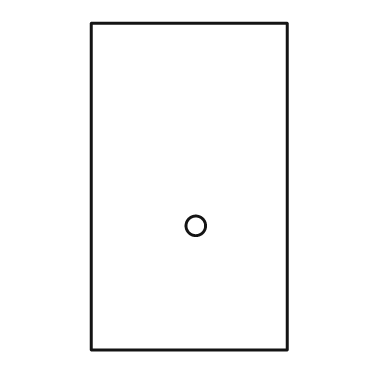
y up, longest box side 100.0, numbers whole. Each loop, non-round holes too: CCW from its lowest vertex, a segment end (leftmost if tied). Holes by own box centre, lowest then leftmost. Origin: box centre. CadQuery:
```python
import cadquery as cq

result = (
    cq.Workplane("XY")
    .moveTo(-30.0, -50.0)
    .lineTo(30.0, -50.0)
    .lineTo(30.0, 50.0)
    .lineTo(-30.0, 50.0)
    .close()
    .moveTo(2.0, -12.0)
    .circle(3.0)
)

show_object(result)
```